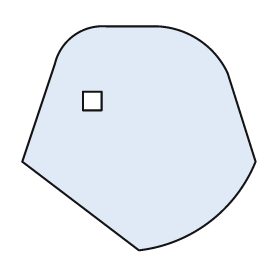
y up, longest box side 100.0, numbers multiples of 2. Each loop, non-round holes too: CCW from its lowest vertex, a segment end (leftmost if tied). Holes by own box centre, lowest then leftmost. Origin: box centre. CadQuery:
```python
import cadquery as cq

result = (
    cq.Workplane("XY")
    .moveTo(0.0, -48.0)
    .threePointArc((30.0, -36.0), (50.0, -10.0))
    .lineTo(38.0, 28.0)
    .threePointArc((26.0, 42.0), (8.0, 48.0))
    .lineTo(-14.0, 48.0)
    .threePointArc((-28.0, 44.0), (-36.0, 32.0))
    .lineTo(-50.0, -10.0)
    .close()
    .moveTo(-24.0, 12.0)
    .lineTo(-16.0, 12.0)
    .lineTo(-16.0, 20.0)
    .lineTo(-24.0, 20.0)
    .close()
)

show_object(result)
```